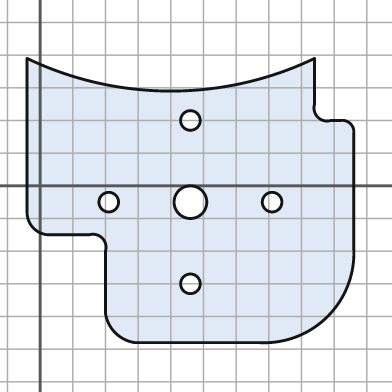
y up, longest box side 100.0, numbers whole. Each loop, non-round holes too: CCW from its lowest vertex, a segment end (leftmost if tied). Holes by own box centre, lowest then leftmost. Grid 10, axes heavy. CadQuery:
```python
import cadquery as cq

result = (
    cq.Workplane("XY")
    .moveTo(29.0, -48.0)
    .lineTo(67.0, -48.0)
    .threePointArc((88.0, -40.0), (96.0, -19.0))
    .lineTo(96.0, 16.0)
    .threePointArc((95.0, 19.0), (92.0, 20.0))
    .lineTo(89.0, 20.0)
    .threePointArc((85.0, 21.0), (84.0, 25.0))
    .lineTo(84.0, 39.0)
    .threePointArc((40.0, 29.0), (-4.0, 39.0))
    .lineTo(-4.0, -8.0)
    .threePointArc((-2.0, -13.0), (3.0, -15.0))
    .lineTo(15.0, -15.0)
    .threePointArc((19.0, -16.0), (20.0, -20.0))
    .lineTo(20.0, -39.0)
    .threePointArc((23.0, -45.0), (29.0, -48.0))
    .close()
    .moveTo(46.0, -30.0)
    .circle(3.0)
    .moveTo(21.0, -5.0)
    .circle(3.0)
    .moveTo(46.0, -5.0)
    .circle(5.0)
    .moveTo(71.0, -5.0)
    .circle(3.0)
    .moveTo(46.0, 20.0)
    .circle(3.0)
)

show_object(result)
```